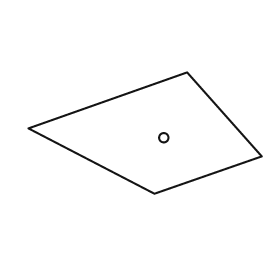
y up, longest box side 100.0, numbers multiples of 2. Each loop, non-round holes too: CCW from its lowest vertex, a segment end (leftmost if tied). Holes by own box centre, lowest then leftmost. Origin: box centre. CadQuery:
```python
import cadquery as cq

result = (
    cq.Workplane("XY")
    .moveTo(4.0, -26.0)
    .lineTo(50.0, -10.0)
    .lineTo(18.0, 26.0)
    .lineTo(-50.0, 2.0)
    .close()
    .moveTo(8.0, -2.0)
    .circle(2.0)
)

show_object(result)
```